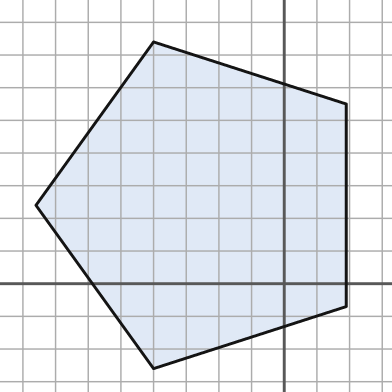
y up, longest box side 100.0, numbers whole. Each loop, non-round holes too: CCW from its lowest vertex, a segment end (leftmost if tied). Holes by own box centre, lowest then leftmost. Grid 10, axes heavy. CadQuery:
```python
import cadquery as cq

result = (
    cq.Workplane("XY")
    .moveTo(-40.0, -26.0)
    .lineTo(19.0, -7.0)
    .lineTo(19.0, 55.0)
    .lineTo(-40.0, 74.0)
    .lineTo(-76.0, 24.0)
    .close()
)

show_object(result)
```